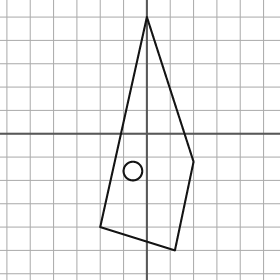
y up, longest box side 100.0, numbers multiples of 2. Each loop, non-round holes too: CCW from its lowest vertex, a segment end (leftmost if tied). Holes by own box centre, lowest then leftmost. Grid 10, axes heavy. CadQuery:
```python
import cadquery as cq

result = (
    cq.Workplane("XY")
    .moveTo(12.0, -50.0)
    .lineTo(20.0, -12.0)
    .lineTo(0.0, 50.0)
    .lineTo(-20.0, -40.0)
    .close()
    .moveTo(-6.0, -16.0)
    .circle(4.0)
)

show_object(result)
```